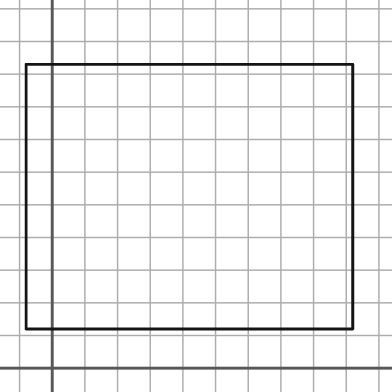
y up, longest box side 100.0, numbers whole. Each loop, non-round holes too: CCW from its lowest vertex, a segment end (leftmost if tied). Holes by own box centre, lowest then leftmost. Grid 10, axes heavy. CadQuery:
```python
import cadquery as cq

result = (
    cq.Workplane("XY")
    .moveTo(-8.0, 12.0)
    .lineTo(92.0, 12.0)
    .lineTo(92.0, 93.0)
    .lineTo(-8.0, 93.0)
    .close()
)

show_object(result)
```